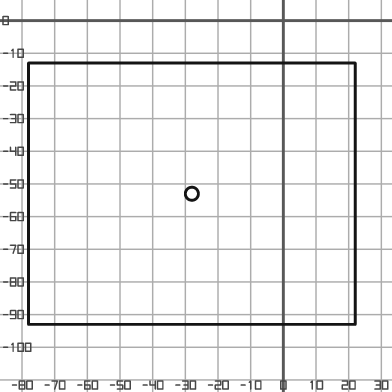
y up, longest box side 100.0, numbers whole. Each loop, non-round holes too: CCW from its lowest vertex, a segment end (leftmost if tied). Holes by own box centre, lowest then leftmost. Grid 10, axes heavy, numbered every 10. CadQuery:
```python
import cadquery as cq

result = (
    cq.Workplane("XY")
    .moveTo(-78.0, -93.0)
    .lineTo(22.0, -93.0)
    .lineTo(22.0, -13.0)
    .lineTo(-78.0, -13.0)
    .close()
    .moveTo(-28.0, -53.0)
    .circle(2.0)
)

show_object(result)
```